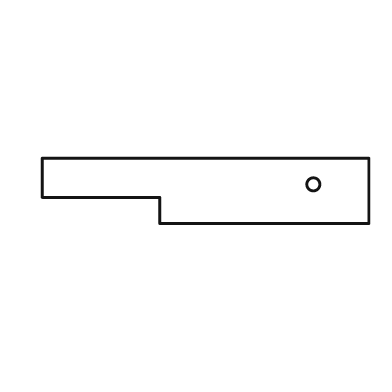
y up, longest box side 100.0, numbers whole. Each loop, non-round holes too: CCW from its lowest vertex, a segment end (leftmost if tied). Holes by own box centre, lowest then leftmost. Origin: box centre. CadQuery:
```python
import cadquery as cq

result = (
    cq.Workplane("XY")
    .moveTo(-14.0, -10.0)
    .lineTo(50.0, -10.0)
    .lineTo(50.0, 10.0)
    .lineTo(-50.0, 10.0)
    .lineTo(-50.0, -2.0)
    .lineTo(-14.0, -2.0)
    .close()
    .moveTo(33.0, 2.0)
    .circle(2.0)
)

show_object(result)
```